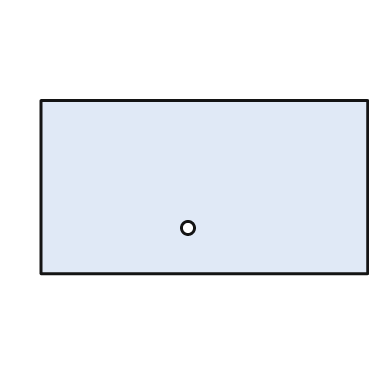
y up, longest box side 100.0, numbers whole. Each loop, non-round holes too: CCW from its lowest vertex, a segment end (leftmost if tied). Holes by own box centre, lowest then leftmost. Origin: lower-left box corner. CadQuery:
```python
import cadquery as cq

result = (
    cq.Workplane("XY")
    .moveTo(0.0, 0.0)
    .lineTo(100.0, 0.0)
    .lineTo(100.0, 53.0)
    .lineTo(0.0, 53.0)
    .close()
    .moveTo(45.0, 14.0)
    .circle(2.0)
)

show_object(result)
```